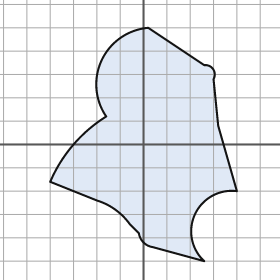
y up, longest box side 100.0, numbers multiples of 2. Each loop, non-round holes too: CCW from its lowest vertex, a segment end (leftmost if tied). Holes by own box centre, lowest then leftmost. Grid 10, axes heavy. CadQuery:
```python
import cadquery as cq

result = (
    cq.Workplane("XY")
    .moveTo(26.0, -50.0)
    .threePointArc((22.0, -30.0), (40.0, -20.0))
    .lineTo(32.0, 8.0)
    .lineTo(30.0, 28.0)
    .threePointArc((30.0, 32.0), (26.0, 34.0))
    .lineTo(2.0, 50.0)
    .threePointArc((-18.0, 36.0), (-16.0, 12.0))
    .threePointArc((-30.0, 0.0), (-40.0, -16.0))
    .lineTo(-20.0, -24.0)
    .threePointArc((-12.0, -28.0), (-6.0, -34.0))
    .lineTo(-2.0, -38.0)
    .threePointArc((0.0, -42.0), (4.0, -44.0))
    .close()
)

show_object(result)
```